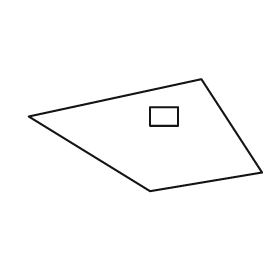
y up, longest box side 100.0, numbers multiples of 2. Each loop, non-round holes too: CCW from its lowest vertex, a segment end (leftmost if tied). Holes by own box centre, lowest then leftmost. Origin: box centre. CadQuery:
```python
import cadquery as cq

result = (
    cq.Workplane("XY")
    .moveTo(2.0, -24.0)
    .lineTo(50.0, -16.0)
    .lineTo(24.0, 24.0)
    .lineTo(-50.0, 8.0)
    .close()
    .moveTo(2.0, 4.0)
    .lineTo(14.0, 4.0)
    .lineTo(14.0, 12.0)
    .lineTo(2.0, 12.0)
    .close()
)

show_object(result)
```